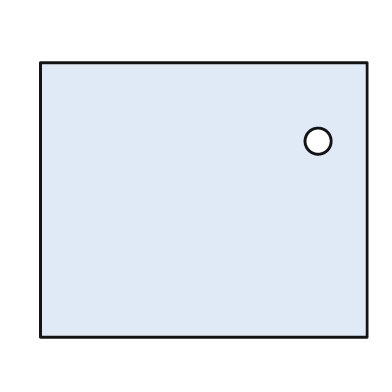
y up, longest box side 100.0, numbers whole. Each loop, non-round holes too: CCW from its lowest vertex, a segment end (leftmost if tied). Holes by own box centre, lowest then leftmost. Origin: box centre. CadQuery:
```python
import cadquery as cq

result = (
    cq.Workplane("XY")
    .moveTo(-50.0, -42.0)
    .lineTo(50.0, -42.0)
    .lineTo(50.0, 42.0)
    .lineTo(-50.0, 42.0)
    .close()
    .moveTo(35.0, 18.0)
    .circle(4.0)
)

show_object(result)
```